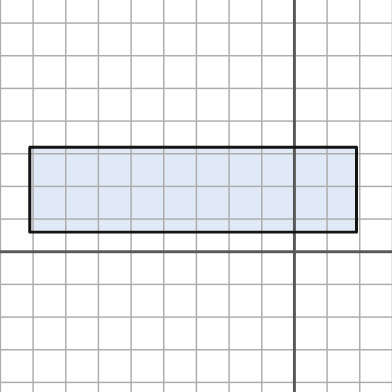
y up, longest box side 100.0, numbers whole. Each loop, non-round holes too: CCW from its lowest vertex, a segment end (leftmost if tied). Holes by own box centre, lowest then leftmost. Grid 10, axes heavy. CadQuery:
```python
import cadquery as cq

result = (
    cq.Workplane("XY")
    .moveTo(-81.0, 6.0)
    .lineTo(19.0, 6.0)
    .lineTo(19.0, 32.0)
    .lineTo(-81.0, 32.0)
    .close()
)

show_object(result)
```